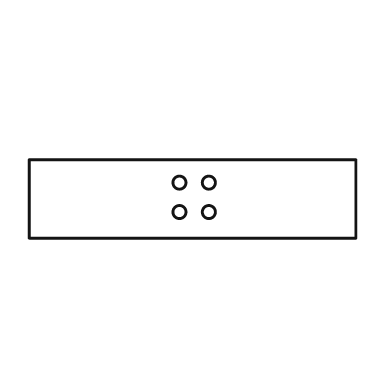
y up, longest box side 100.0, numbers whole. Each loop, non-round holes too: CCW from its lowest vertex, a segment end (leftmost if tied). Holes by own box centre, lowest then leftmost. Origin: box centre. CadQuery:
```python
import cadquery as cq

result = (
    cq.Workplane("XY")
    .moveTo(-50.0, -12.0)
    .lineTo(50.0, -12.0)
    .lineTo(50.0, 12.0)
    .lineTo(-50.0, 12.0)
    .close()
    .moveTo(-4.0, -4.0)
    .circle(2.0)
    .moveTo(5.0, -4.0)
    .circle(2.0)
    .moveTo(-4.0, 5.0)
    .circle(2.0)
    .moveTo(5.0, 5.0)
    .circle(2.0)
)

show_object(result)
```